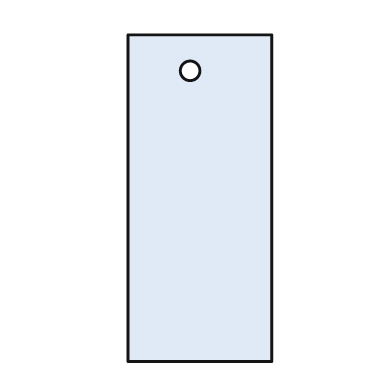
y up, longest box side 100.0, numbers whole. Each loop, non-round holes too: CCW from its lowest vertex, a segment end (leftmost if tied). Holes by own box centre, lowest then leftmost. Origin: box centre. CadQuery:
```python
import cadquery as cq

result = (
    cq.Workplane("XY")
    .moveTo(-22.0, -50.0)
    .lineTo(22.0, -50.0)
    .lineTo(22.0, 50.0)
    .lineTo(-22.0, 50.0)
    .close()
    .moveTo(-3.0, 39.0)
    .circle(3.0)
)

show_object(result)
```